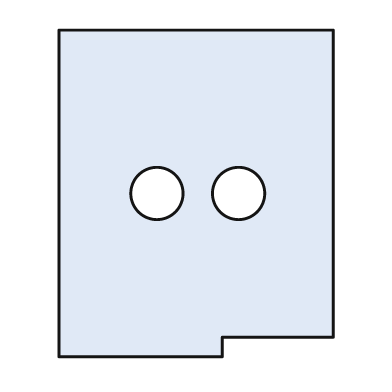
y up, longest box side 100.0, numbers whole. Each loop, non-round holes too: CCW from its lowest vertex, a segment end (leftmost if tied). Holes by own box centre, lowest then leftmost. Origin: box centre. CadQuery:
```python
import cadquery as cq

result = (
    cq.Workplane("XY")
    .moveTo(-42.0, -50.0)
    .lineTo(8.0, -50.0)
    .lineTo(8.0, -44.0)
    .lineTo(42.0, -44.0)
    .lineTo(42.0, 50.0)
    .lineTo(-42.0, 50.0)
    .close()
    .moveTo(-12.0, 0.0)
    .circle(8.0)
    .moveTo(13.0, 0.0)
    .circle(8.0)
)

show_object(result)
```